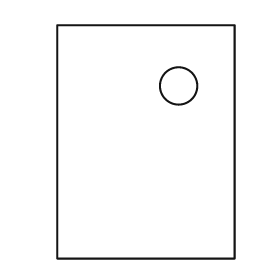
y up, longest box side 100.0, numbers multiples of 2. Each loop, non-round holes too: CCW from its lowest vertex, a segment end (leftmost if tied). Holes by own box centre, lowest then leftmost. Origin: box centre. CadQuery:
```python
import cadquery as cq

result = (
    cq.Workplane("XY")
    .moveTo(-38.0, -50.0)
    .lineTo(38.0, -50.0)
    .lineTo(38.0, 50.0)
    .lineTo(-38.0, 50.0)
    .close()
    .moveTo(14.0, 24.0)
    .circle(8.0)
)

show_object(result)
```